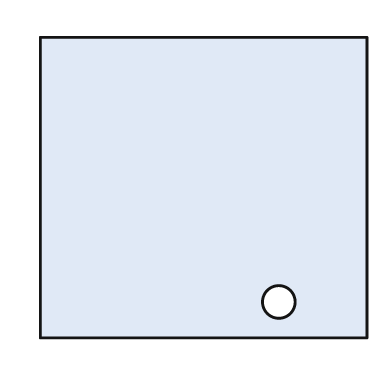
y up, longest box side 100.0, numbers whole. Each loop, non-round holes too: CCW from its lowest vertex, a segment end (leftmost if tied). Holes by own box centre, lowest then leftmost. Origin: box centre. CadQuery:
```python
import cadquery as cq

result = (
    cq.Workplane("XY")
    .moveTo(-50.0, -46.0)
    .lineTo(50.0, -46.0)
    .lineTo(50.0, 46.0)
    .lineTo(-50.0, 46.0)
    .close()
    .moveTo(23.0, -35.0)
    .circle(5.0)
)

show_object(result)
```